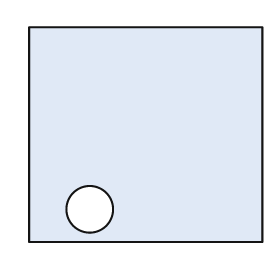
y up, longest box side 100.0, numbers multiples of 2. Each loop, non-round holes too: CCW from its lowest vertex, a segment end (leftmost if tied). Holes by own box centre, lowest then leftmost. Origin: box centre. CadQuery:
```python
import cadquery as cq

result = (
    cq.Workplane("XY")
    .moveTo(-50.0, -46.0)
    .lineTo(50.0, -46.0)
    .lineTo(50.0, 46.0)
    .lineTo(-50.0, 46.0)
    .close()
    .moveTo(-24.0, -32.0)
    .circle(10.0)
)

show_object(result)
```